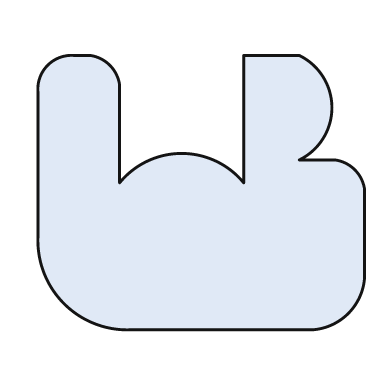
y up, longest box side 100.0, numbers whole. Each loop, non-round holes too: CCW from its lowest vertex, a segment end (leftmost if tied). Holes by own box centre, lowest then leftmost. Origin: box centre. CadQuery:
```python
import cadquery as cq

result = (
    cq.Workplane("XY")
    .moveTo(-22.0, -42.0)
    .lineTo(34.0, -42.0)
    .threePointArc((45.0, -37.0), (50.0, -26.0))
    .lineTo(50.0, 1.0)
    .threePointArc((47.0, 7.0), (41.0, 10.0))
    .lineTo(30.0, 10.0)
    .threePointArc((40.0, 26.0), (30.0, 42.0))
    .lineTo(13.0, 42.0)
    .lineTo(13.0, 3.0)
    .threePointArc((-6.0, 12.0), (-25.0, 3.0))
    .lineTo(-25.0, 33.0)
    .threePointArc((-28.0, 39.0), (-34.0, 42.0))
    .lineTo(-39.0, 42.0)
    .threePointArc((-47.0, 39.0), (-50.0, 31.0))
    .lineTo(-50.0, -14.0)
    .threePointArc((-42.0, -34.0), (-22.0, -42.0))
    .close()
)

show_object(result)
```